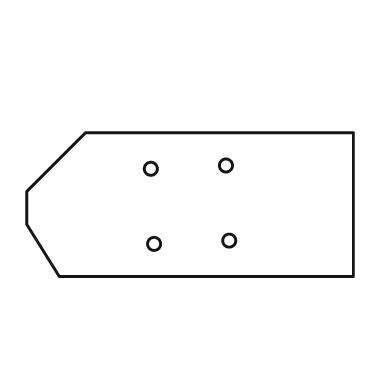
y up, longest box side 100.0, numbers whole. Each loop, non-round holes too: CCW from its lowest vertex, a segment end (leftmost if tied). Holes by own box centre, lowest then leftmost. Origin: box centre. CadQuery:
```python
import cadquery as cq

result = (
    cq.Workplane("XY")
    .moveTo(-40.0, -22.0)
    .lineTo(50.0, -22.0)
    .lineTo(50.0, 22.0)
    .lineTo(-32.0, 22.0)
    .lineTo(-50.0, 4.0)
    .lineTo(-50.0, -6.0)
    .close()
    .moveTo(-11.0, -12.0)
    .circle(2.0)
    .moveTo(12.0, -11.0)
    .circle(2.0)
    .moveTo(-12.0, 11.0)
    .circle(2.0)
    .moveTo(11.0, 12.0)
    .circle(2.0)
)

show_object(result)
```